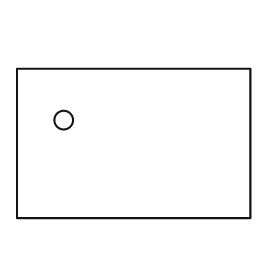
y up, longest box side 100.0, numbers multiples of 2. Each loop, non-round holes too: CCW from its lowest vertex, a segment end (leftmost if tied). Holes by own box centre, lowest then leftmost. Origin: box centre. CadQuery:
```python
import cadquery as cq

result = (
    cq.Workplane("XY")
    .moveTo(-50.0, -32.0)
    .lineTo(50.0, -32.0)
    .lineTo(50.0, 32.0)
    .lineTo(-50.0, 32.0)
    .close()
    .moveTo(-30.0, 10.0)
    .circle(4.0)
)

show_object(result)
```